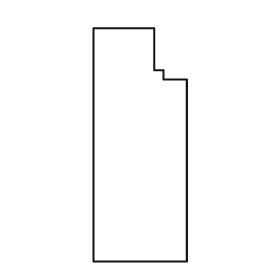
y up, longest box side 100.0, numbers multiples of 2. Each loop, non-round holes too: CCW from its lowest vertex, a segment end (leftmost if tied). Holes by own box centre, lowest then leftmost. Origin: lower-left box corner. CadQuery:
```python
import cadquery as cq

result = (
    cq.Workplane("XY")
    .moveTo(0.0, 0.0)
    .lineTo(40.0, 0.0)
    .lineTo(40.0, 78.0)
    .lineTo(30.0, 78.0)
    .lineTo(30.0, 82.0)
    .lineTo(26.0, 82.0)
    .lineTo(26.0, 100.0)
    .lineTo(0.0, 100.0)
    .close()
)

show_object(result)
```